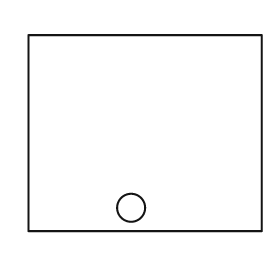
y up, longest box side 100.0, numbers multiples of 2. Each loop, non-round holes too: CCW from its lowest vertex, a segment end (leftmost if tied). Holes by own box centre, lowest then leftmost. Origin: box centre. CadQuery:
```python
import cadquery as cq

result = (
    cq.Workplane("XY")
    .moveTo(-50.0, -42.0)
    .lineTo(50.0, -42.0)
    .lineTo(50.0, 42.0)
    .lineTo(-50.0, 42.0)
    .close()
    .moveTo(-6.0, -32.0)
    .circle(6.0)
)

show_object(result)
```